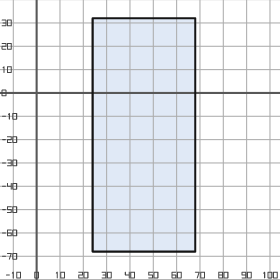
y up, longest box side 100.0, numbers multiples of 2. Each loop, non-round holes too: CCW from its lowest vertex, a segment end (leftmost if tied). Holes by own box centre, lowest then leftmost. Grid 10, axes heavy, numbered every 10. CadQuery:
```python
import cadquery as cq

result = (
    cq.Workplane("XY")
    .moveTo(24.0, -68.0)
    .lineTo(68.0, -68.0)
    .lineTo(68.0, 32.0)
    .lineTo(24.0, 32.0)
    .close()
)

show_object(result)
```